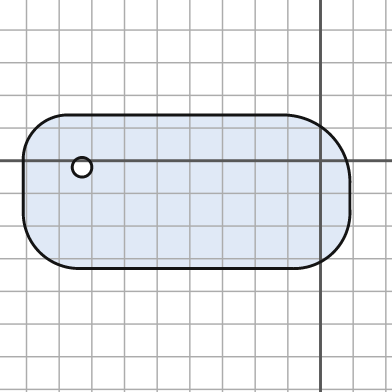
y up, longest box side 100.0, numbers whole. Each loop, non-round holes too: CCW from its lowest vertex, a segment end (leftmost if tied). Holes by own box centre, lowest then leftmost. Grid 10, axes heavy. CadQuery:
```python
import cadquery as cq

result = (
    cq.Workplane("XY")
    .moveTo(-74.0, -33.0)
    .lineTo(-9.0, -33.0)
    .threePointArc((4.0, -28.0), (9.0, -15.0))
    .lineTo(9.0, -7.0)
    .threePointArc((3.0, 8.0), (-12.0, 14.0))
    .lineTo(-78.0, 14.0)
    .threePointArc((-87.0, 10.0), (-91.0, 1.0))
    .lineTo(-91.0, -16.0)
    .threePointArc((-86.0, -28.0), (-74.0, -33.0))
    .close()
    .moveTo(-73.0, -2.0)
    .circle(3.0)
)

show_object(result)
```